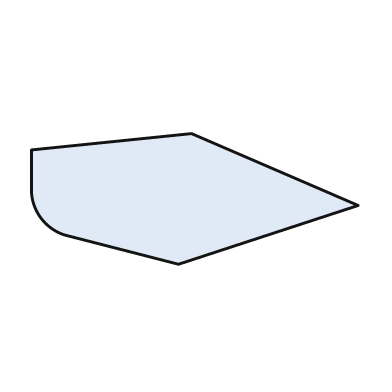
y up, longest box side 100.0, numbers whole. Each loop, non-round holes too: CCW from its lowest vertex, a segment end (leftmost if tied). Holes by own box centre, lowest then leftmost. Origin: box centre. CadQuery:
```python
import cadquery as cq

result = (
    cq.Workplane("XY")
    .moveTo(-5.0, -20.0)
    .lineTo(50.0, -2.0)
    .lineTo(-1.0, 20.0)
    .lineTo(-50.0, 15.0)
    .lineTo(-50.0, 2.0)
    .threePointArc((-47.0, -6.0), (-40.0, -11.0))
    .close()
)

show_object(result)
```